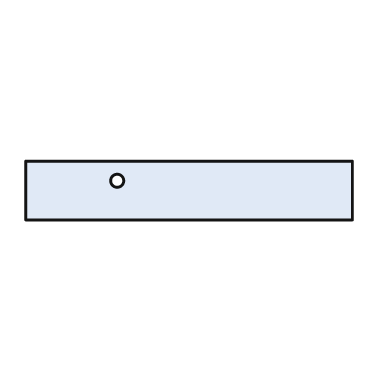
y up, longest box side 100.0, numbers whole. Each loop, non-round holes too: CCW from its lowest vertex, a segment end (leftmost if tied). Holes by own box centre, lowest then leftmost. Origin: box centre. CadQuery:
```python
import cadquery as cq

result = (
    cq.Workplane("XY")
    .moveTo(-50.0, -9.0)
    .lineTo(50.0, -9.0)
    .lineTo(50.0, 9.0)
    .lineTo(-50.0, 9.0)
    .close()
    .moveTo(-22.0, 3.0)
    .circle(2.0)
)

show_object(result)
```